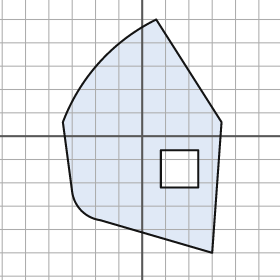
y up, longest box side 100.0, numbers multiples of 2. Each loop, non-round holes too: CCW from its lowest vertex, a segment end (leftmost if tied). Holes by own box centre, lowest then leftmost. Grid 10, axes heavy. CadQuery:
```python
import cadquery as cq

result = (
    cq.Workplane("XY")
    .moveTo(30.0, -50.0)
    .lineTo(34.0, 6.0)
    .lineTo(6.0, 50.0)
    .threePointArc((-18.0, 32.0), (-34.0, 6.0))
    .lineTo(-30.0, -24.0)
    .threePointArc((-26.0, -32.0), (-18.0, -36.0))
    .close()
    .moveTo(8.0, -22.0)
    .lineTo(24.0, -22.0)
    .lineTo(24.0, -6.0)
    .lineTo(8.0, -6.0)
    .close()
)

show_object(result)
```